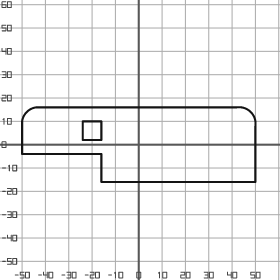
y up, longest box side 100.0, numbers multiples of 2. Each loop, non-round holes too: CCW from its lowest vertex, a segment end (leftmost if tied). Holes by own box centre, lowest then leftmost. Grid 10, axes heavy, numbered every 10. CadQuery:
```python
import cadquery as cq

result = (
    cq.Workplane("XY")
    .moveTo(-16.0, -16.0)
    .lineTo(50.0, -16.0)
    .lineTo(50.0, 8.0)
    .threePointArc((48.0, 14.0), (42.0, 16.0))
    .lineTo(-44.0, 16.0)
    .threePointArc((-48.0, 14.0), (-50.0, 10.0))
    .lineTo(-50.0, -4.0)
    .lineTo(-16.0, -4.0)
    .close()
    .moveTo(-24.0, 2.0)
    .lineTo(-16.0, 2.0)
    .lineTo(-16.0, 10.0)
    .lineTo(-24.0, 10.0)
    .close()
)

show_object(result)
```